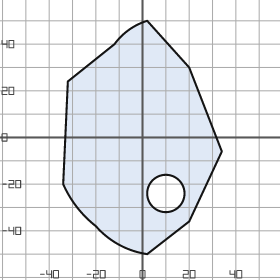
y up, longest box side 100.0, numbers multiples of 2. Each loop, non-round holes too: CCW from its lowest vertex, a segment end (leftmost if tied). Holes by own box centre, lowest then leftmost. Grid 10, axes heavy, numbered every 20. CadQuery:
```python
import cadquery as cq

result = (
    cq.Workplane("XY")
    .moveTo(2.0, -50.0)
    .lineTo(20.0, -36.0)
    .lineTo(34.0, -6.0)
    .lineTo(20.0, 30.0)
    .lineTo(2.0, 50.0)
    .threePointArc((-6.0, 46.0), (-12.0, 40.0))
    .lineTo(-32.0, 24.0)
    .lineTo(-34.0, -20.0)
    .threePointArc((-28.0, -30.0), (-20.0, -38.0))
    .threePointArc((-10.0, -46.0), (2.0, -50.0))
    .close()
    .moveTo(10.0, -24.0)
    .circle(8.0)
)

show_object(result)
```